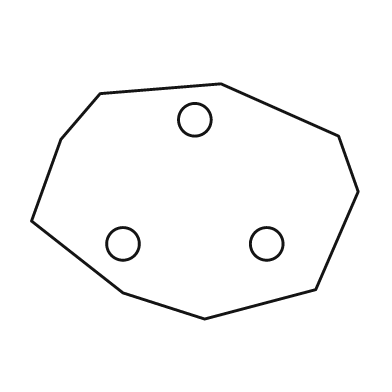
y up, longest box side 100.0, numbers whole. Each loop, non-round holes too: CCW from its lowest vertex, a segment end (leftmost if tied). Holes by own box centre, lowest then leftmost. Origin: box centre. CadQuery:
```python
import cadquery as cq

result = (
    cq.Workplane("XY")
    .moveTo(3.0, -36.0)
    .lineTo(37.0, -27.0)
    .lineTo(50.0, 3.0)
    .lineTo(44.0, 20.0)
    .lineTo(8.0, 36.0)
    .lineTo(-29.0, 33.0)
    .lineTo(-41.0, 19.0)
    .lineTo(-50.0, -6.0)
    .lineTo(-22.0, -28.0)
    .close()
    .moveTo(-22.0, -13.0)
    .circle(5.0)
    .moveTo(22.0, -13.0)
    .circle(5.0)
    .moveTo(0.0, 25.0)
    .circle(5.0)
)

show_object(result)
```